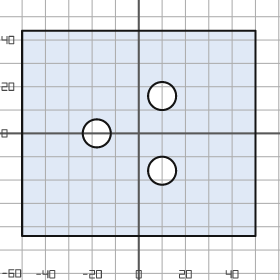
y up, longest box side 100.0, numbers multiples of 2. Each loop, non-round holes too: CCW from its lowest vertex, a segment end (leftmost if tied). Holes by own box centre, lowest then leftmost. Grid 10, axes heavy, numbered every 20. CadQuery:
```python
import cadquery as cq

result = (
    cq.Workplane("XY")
    .moveTo(-50.0, -44.0)
    .lineTo(50.0, -44.0)
    .lineTo(50.0, 44.0)
    .lineTo(-50.0, 44.0)
    .close()
    .moveTo(10.0, -16.0)
    .circle(6.0)
    .moveTo(-18.0, 0.0)
    .circle(6.0)
    .moveTo(10.0, 16.0)
    .circle(6.0)
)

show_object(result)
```